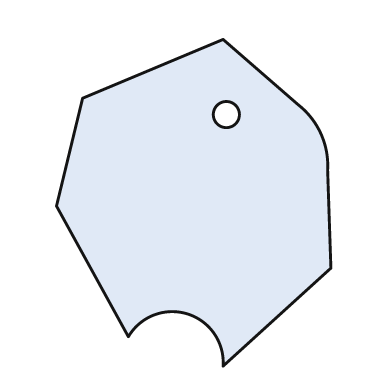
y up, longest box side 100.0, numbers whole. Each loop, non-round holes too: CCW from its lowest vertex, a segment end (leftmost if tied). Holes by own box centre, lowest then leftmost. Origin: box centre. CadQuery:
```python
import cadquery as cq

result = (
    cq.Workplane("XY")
    .moveTo(9.0, -50.0)
    .lineTo(42.0, -20.0)
    .lineTo(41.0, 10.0)
    .threePointArc((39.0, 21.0), (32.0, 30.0))
    .lineTo(9.0, 50.0)
    .lineTo(-34.0, 32.0)
    .lineTo(-42.0, -1.0)
    .lineTo(-20.0, -41.0)
    .threePointArc((-2.0, -34.0), (9.0, -50.0))
    .close()
    .moveTo(10.0, 27.0)
    .circle(4.0)
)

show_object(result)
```